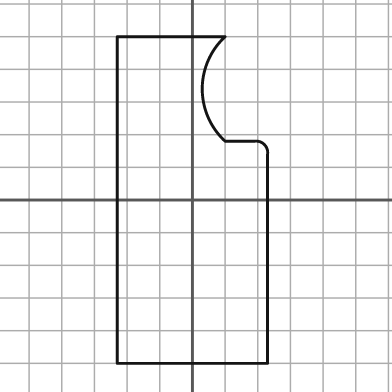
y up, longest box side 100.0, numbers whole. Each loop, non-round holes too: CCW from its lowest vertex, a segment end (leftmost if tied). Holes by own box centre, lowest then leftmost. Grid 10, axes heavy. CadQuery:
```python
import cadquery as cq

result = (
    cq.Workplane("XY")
    .moveTo(-23.0, -50.0)
    .lineTo(23.0, -50.0)
    .lineTo(23.0, 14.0)
    .threePointArc((22.0, 17.0), (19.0, 18.0))
    .lineTo(10.0, 18.0)
    .threePointArc((3.0, 34.0), (10.0, 50.0))
    .lineTo(-23.0, 50.0)
    .close()
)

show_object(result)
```